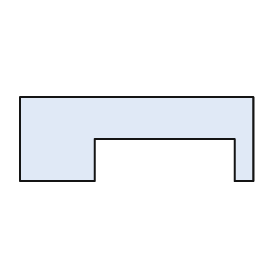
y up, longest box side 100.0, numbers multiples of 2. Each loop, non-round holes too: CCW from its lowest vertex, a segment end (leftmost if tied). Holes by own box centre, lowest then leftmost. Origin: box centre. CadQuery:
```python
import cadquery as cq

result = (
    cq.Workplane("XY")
    .moveTo(-50.0, -18.0)
    .lineTo(-18.0, -18.0)
    .lineTo(-18.0, 0.0)
    .lineTo(42.0, 0.0)
    .lineTo(42.0, -18.0)
    .lineTo(50.0, -18.0)
    .lineTo(50.0, 18.0)
    .lineTo(-50.0, 18.0)
    .close()
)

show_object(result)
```